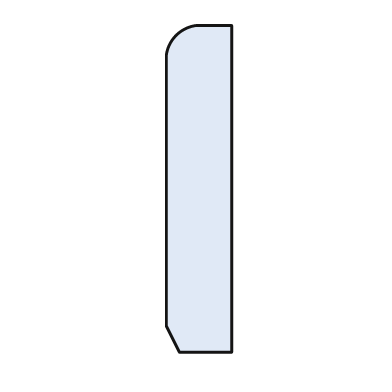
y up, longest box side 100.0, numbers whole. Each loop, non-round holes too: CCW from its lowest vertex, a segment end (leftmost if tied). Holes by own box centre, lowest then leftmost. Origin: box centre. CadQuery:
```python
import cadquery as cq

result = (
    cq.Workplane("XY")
    .moveTo(-6.0, -50.0)
    .lineTo(10.0, -50.0)
    .lineTo(10.0, 50.0)
    .lineTo(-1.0, 50.0)
    .threePointArc((-7.0, 47.0), (-10.0, 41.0))
    .lineTo(-10.0, -42.0)
    .close()
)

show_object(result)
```